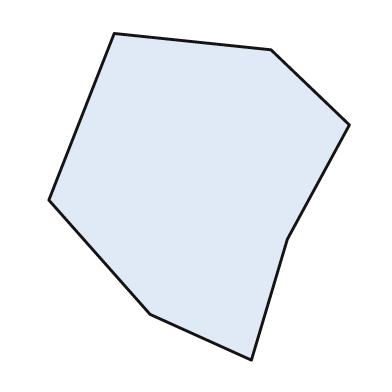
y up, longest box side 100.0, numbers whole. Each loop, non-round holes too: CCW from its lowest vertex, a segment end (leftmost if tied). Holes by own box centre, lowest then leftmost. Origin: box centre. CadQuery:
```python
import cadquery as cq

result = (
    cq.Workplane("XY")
    .moveTo(16.0, -50.0)
    .lineTo(27.0, -13.0)
    .lineTo(46.0, 22.0)
    .lineTo(22.0, 45.0)
    .lineTo(-26.0, 50.0)
    .lineTo(-46.0, -1.0)
    .lineTo(-15.0, -36.0)
    .close()
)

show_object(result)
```